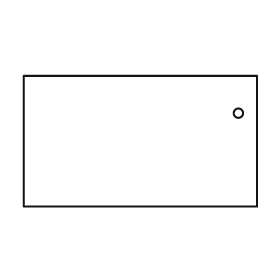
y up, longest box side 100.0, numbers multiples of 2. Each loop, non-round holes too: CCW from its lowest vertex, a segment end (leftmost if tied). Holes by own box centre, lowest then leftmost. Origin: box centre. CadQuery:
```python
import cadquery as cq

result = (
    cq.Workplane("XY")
    .moveTo(-50.0, -28.0)
    .lineTo(50.0, -28.0)
    .lineTo(50.0, 28.0)
    .lineTo(-50.0, 28.0)
    .close()
    .moveTo(42.0, 12.0)
    .circle(2.0)
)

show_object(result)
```